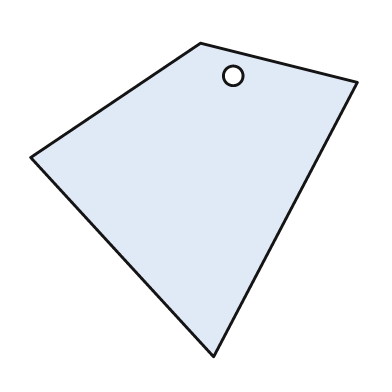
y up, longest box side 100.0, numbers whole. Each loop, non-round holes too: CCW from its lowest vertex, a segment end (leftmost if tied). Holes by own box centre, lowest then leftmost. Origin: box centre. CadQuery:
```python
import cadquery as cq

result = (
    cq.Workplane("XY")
    .moveTo(6.0, -48.0)
    .lineTo(50.0, 36.0)
    .lineTo(2.0, 48.0)
    .lineTo(-50.0, 13.0)
    .close()
    .moveTo(12.0, 38.0)
    .circle(3.0)
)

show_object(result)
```